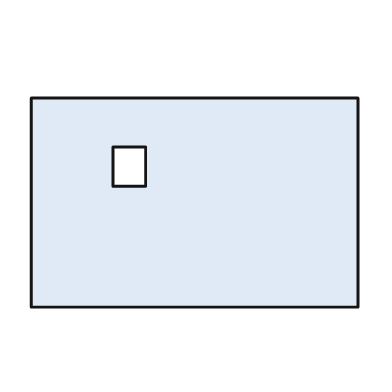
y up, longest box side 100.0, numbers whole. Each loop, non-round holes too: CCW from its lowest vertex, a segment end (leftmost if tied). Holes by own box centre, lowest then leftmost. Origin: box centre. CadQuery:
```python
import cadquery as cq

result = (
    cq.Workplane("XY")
    .moveTo(-50.0, -32.0)
    .lineTo(50.0, -32.0)
    .lineTo(50.0, 32.0)
    .lineTo(-50.0, 32.0)
    .close()
    .moveTo(-25.0, 5.0)
    .lineTo(-15.0, 5.0)
    .lineTo(-15.0, 17.0)
    .lineTo(-25.0, 17.0)
    .close()
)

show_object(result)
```